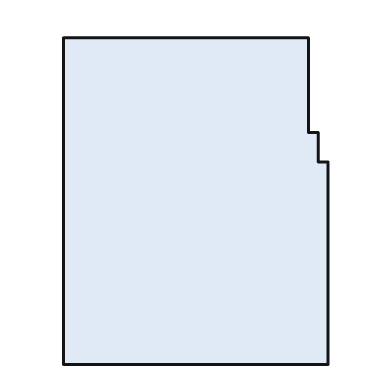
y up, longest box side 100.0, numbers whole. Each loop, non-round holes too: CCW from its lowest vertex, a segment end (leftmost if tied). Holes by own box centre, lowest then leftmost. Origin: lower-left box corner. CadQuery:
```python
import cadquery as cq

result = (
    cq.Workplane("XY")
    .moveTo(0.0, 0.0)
    .lineTo(81.0, 0.0)
    .lineTo(81.0, 62.0)
    .lineTo(78.0, 62.0)
    .lineTo(78.0, 71.0)
    .lineTo(75.0, 71.0)
    .lineTo(75.0, 100.0)
    .lineTo(0.0, 100.0)
    .close()
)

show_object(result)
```